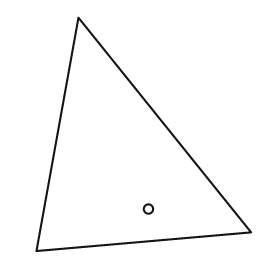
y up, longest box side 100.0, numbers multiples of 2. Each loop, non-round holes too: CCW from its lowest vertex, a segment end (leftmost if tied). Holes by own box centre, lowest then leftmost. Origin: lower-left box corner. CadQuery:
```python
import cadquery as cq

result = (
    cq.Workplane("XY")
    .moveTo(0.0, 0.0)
    .lineTo(92.0, 8.0)
    .lineTo(18.0, 100.0)
    .close()
    .moveTo(48.0, 18.0)
    .circle(2.0)
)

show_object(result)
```